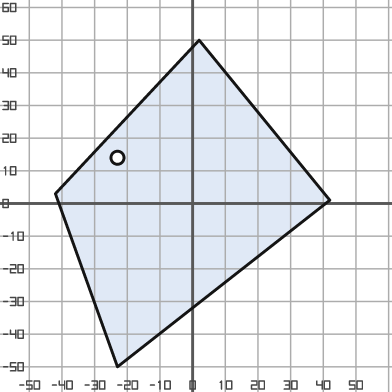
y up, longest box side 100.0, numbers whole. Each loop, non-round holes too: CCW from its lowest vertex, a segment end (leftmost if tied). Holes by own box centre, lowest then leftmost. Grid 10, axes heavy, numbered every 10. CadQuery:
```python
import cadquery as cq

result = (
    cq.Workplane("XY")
    .moveTo(-23.0, -50.0)
    .lineTo(42.0, 1.0)
    .lineTo(2.0, 50.0)
    .lineTo(-42.0, 3.0)
    .close()
    .moveTo(-23.0, 14.0)
    .circle(2.0)
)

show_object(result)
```